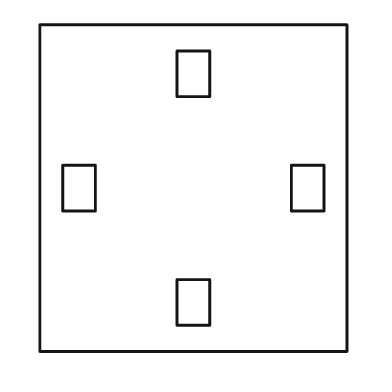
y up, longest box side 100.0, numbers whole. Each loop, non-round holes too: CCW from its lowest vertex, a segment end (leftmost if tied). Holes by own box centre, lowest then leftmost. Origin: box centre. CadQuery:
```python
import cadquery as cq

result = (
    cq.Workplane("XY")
    .moveTo(-47.0, -50.0)
    .lineTo(47.0, -50.0)
    .lineTo(47.0, 50.0)
    .lineTo(-47.0, 50.0)
    .close()
    .moveTo(-5.0, -42.0)
    .lineTo(5.0, -42.0)
    .lineTo(5.0, -28.0)
    .lineTo(-5.0, -28.0)
    .close()
    .moveTo(-40.0, -7.0)
    .lineTo(-30.0, -7.0)
    .lineTo(-30.0, 7.0)
    .lineTo(-40.0, 7.0)
    .close()
    .moveTo(30.0, -7.0)
    .lineTo(40.0, -7.0)
    .lineTo(40.0, 7.0)
    .lineTo(30.0, 7.0)
    .close()
    .moveTo(-5.0, 28.0)
    .lineTo(5.0, 28.0)
    .lineTo(5.0, 42.0)
    .lineTo(-5.0, 42.0)
    .close()
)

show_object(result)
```